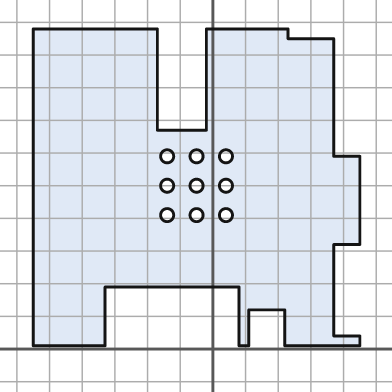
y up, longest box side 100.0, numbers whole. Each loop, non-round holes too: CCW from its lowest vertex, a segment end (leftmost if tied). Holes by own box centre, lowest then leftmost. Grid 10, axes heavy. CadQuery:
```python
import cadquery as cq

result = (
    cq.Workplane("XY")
    .moveTo(-55.0, 1.0)
    .lineTo(-33.0, 1.0)
    .lineTo(-33.0, 19.0)
    .lineTo(8.0, 19.0)
    .lineTo(8.0, 1.0)
    .lineTo(11.0, 1.0)
    .lineTo(11.0, 12.0)
    .lineTo(22.0, 12.0)
    .lineTo(22.0, 1.0)
    .lineTo(45.0, 1.0)
    .lineTo(45.0, 4.0)
    .lineTo(37.0, 4.0)
    .lineTo(37.0, 32.0)
    .lineTo(45.0, 32.0)
    .lineTo(45.0, 59.0)
    .lineTo(37.0, 59.0)
    .lineTo(37.0, 95.0)
    .lineTo(23.0, 95.0)
    .lineTo(23.0, 98.0)
    .lineTo(-2.0, 98.0)
    .lineTo(-2.0, 67.0)
    .lineTo(-17.0, 67.0)
    .lineTo(-17.0, 98.0)
    .lineTo(-55.0, 98.0)
    .close()
    .moveTo(-14.0, 41.0)
    .circle(2.0)
    .moveTo(-5.0, 41.0)
    .circle(2.0)
    .moveTo(4.0, 41.0)
    .circle(2.0)
    .moveTo(-14.0, 50.0)
    .circle(2.0)
    .moveTo(-5.0, 50.0)
    .circle(2.0)
    .moveTo(4.0, 50.0)
    .circle(2.0)
    .moveTo(-14.0, 59.0)
    .circle(2.0)
    .moveTo(-5.0, 59.0)
    .circle(2.0)
    .moveTo(4.0, 59.0)
    .circle(2.0)
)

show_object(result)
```